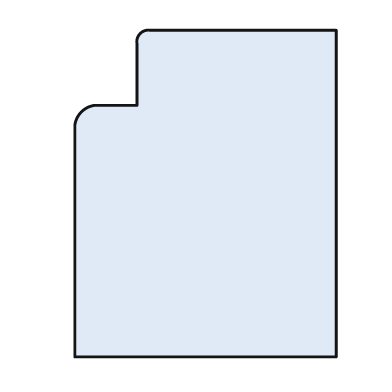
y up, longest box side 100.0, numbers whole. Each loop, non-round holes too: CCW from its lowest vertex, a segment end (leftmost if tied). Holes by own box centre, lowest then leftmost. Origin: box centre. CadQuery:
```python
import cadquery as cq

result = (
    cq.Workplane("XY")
    .moveTo(-40.0, -50.0)
    .lineTo(40.0, -50.0)
    .lineTo(40.0, 50.0)
    .lineTo(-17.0, 50.0)
    .threePointArc((-20.0, 49.0), (-21.0, 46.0))
    .lineTo(-21.0, 27.0)
    .lineTo(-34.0, 27.0)
    .threePointArc((-38.0, 25.0), (-40.0, 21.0))
    .close()
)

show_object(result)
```